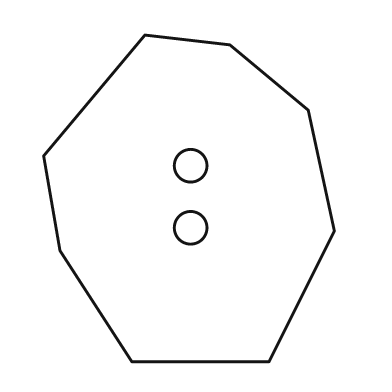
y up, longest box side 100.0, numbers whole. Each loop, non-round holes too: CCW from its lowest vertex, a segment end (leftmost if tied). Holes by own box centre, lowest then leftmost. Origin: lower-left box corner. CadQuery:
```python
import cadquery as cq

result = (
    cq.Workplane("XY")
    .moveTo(27.0, 0.0)
    .lineTo(69.0, 0.0)
    .lineTo(89.0, 40.0)
    .lineTo(81.0, 77.0)
    .lineTo(57.0, 97.0)
    .lineTo(31.0, 100.0)
    .lineTo(0.0, 63.0)
    .lineTo(5.0, 34.0)
    .close()
    .moveTo(45.0, 41.0)
    .circle(5.0)
    .moveTo(45.0, 60.0)
    .circle(5.0)
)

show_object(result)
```